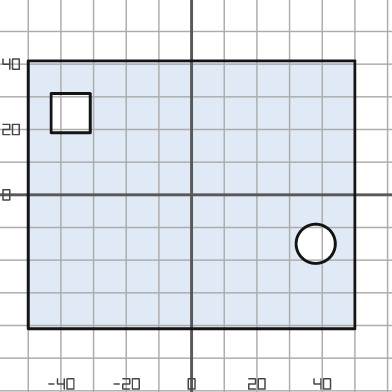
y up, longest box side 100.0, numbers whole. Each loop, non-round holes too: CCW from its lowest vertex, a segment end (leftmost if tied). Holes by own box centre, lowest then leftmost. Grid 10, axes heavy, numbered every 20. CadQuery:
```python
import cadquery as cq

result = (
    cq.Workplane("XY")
    .moveTo(-50.0, -41.0)
    .lineTo(50.0, -41.0)
    .lineTo(50.0, 41.0)
    .lineTo(-50.0, 41.0)
    .close()
    .moveTo(38.0, -15.0)
    .circle(6.0)
    .moveTo(-43.0, 19.0)
    .lineTo(-31.0, 19.0)
    .lineTo(-31.0, 31.0)
    .lineTo(-43.0, 31.0)
    .close()
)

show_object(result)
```